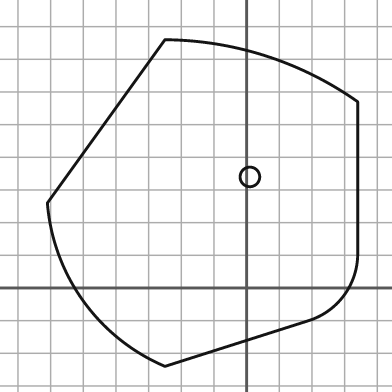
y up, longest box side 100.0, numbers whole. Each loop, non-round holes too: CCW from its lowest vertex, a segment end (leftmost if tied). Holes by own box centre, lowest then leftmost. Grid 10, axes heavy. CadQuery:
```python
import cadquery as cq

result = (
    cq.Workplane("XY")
    .moveTo(-25.0, -24.0)
    .lineTo(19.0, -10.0)
    .threePointArc((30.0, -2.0), (34.0, 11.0))
    .lineTo(34.0, 57.0)
    .threePointArc((6.0, 71.0), (-25.0, 76.0))
    .lineTo(-61.0, 26.0)
    .threePointArc((-50.0, -4.0), (-25.0, -24.0))
    .close()
    .moveTo(1.0, 34.0)
    .circle(3.0)
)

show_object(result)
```